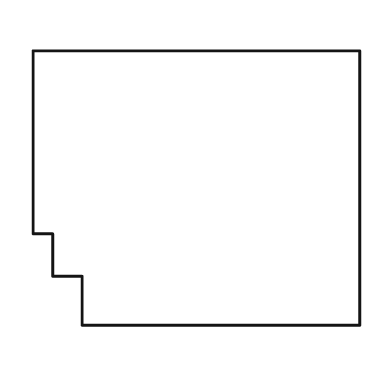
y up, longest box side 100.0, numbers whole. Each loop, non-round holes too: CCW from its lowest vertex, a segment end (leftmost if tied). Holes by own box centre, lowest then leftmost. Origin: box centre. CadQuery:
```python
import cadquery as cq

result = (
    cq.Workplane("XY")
    .moveTo(-35.0, -42.0)
    .lineTo(50.0, -42.0)
    .lineTo(50.0, 42.0)
    .lineTo(-50.0, 42.0)
    .lineTo(-50.0, -14.0)
    .lineTo(-44.0, -14.0)
    .lineTo(-44.0, -27.0)
    .lineTo(-35.0, -27.0)
    .close()
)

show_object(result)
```